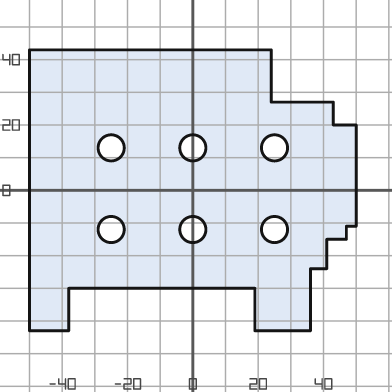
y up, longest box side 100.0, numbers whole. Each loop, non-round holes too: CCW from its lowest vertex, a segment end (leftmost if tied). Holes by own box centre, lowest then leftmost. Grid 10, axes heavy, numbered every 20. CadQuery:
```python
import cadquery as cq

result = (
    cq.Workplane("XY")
    .moveTo(-50.0, -43.0)
    .lineTo(-38.0, -43.0)
    .lineTo(-38.0, -30.0)
    .lineTo(19.0, -30.0)
    .lineTo(19.0, -43.0)
    .lineTo(36.0, -43.0)
    .lineTo(36.0, -24.0)
    .lineTo(41.0, -24.0)
    .lineTo(41.0, -15.0)
    .lineTo(47.0, -15.0)
    .lineTo(47.0, -11.0)
    .lineTo(50.0, -11.0)
    .lineTo(50.0, 20.0)
    .lineTo(43.0, 20.0)
    .lineTo(43.0, 27.0)
    .lineTo(24.0, 27.0)
    .lineTo(24.0, 43.0)
    .lineTo(-50.0, 43.0)
    .close()
    .moveTo(-25.0, -12.0)
    .circle(4.0)
    .moveTo(0.0, -12.0)
    .circle(4.0)
    .moveTo(25.0, -12.0)
    .circle(4.0)
    .moveTo(-25.0, 13.0)
    .circle(4.0)
    .moveTo(0.0, 13.0)
    .circle(4.0)
    .moveTo(25.0, 13.0)
    .circle(4.0)
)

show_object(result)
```